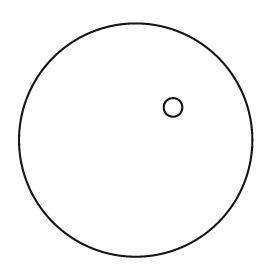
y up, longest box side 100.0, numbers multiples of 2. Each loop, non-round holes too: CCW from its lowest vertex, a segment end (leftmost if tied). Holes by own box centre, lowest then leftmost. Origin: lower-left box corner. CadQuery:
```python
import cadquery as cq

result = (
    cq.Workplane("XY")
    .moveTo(50.0, 50.0)
    .circle(50.0)
    .moveTo(66.0, 64.0)
    .circle(4.0)
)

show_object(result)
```